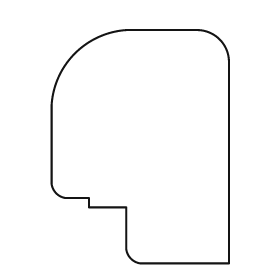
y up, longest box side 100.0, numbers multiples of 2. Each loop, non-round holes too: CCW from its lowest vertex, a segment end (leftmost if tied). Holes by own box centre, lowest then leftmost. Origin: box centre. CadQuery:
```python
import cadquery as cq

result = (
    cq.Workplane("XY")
    .moveTo(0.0, -50.0)
    .lineTo(38.0, -50.0)
    .lineTo(38.0, 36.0)
    .threePointArc((34.0, 46.0), (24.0, 50.0))
    .lineTo(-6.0, 50.0)
    .threePointArc((-28.0, 40.0), (-38.0, 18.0))
    .lineTo(-38.0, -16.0)
    .threePointArc((-36.0, -20.0), (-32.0, -22.0))
    .lineTo(-22.0, -22.0)
    .lineTo(-22.0, -26.0)
    .lineTo(-6.0, -26.0)
    .lineTo(-6.0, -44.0)
    .threePointArc((-4.0, -48.0), (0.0, -50.0))
    .close()
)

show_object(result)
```